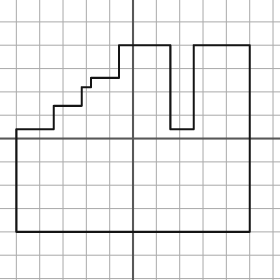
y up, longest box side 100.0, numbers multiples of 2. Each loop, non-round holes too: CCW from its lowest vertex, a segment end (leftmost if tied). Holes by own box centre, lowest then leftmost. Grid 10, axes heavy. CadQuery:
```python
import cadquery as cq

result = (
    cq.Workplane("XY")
    .moveTo(-50.0, -40.0)
    .lineTo(50.0, -40.0)
    .lineTo(50.0, 40.0)
    .lineTo(26.0, 40.0)
    .lineTo(26.0, 4.0)
    .lineTo(16.0, 4.0)
    .lineTo(16.0, 40.0)
    .lineTo(-6.0, 40.0)
    .lineTo(-6.0, 26.0)
    .lineTo(-18.0, 26.0)
    .lineTo(-18.0, 22.0)
    .lineTo(-22.0, 22.0)
    .lineTo(-22.0, 14.0)
    .lineTo(-34.0, 14.0)
    .lineTo(-34.0, 4.0)
    .lineTo(-50.0, 4.0)
    .close()
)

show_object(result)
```